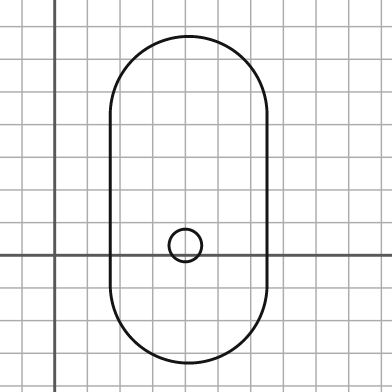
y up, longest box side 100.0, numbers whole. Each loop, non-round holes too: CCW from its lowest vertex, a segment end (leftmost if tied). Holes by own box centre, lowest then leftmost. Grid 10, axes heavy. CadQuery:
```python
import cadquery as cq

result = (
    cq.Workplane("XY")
    .moveTo(17.0, -9.0)
    .threePointArc((41.0, -33.0), (65.0, -9.0))
    .lineTo(65.0, 43.0)
    .threePointArc((41.0, 67.0), (17.0, 43.0))
    .close()
    .moveTo(40.0, 3.0)
    .circle(5.0)
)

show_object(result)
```